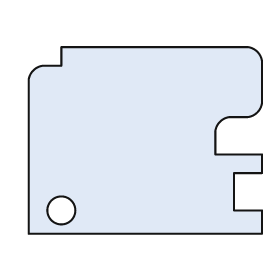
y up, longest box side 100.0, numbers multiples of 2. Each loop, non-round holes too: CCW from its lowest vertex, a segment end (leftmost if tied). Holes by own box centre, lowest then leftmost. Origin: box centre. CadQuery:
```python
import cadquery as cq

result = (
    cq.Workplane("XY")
    .moveTo(-50.0, -40.0)
    .lineTo(50.0, -40.0)
    .lineTo(50.0, -30.0)
    .lineTo(38.0, -30.0)
    .lineTo(38.0, -14.0)
    .lineTo(50.0, -14.0)
    .lineTo(50.0, -6.0)
    .lineTo(30.0, -6.0)
    .lineTo(30.0, 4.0)
    .threePointArc((32.0, 8.0), (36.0, 10.0))
    .lineTo(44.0, 10.0)
    .threePointArc((48.0, 12.0), (50.0, 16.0))
    .lineTo(50.0, 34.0)
    .threePointArc((48.0, 38.0), (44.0, 40.0))
    .lineTo(-36.0, 40.0)
    .lineTo(-36.0, 32.0)
    .lineTo(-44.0, 32.0)
    .threePointArc((-48.0, 30.0), (-50.0, 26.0))
    .close()
    .moveTo(-36.0, -30.0)
    .circle(6.0)
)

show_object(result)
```